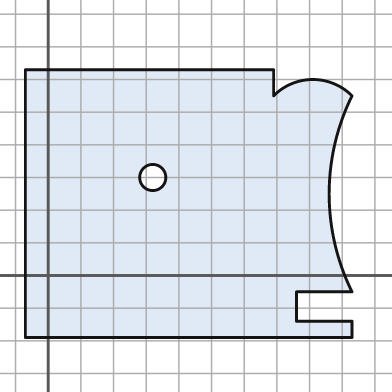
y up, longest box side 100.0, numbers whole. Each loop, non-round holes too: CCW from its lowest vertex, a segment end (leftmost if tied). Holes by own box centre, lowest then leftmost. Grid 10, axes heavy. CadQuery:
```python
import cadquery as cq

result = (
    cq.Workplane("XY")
    .moveTo(-7.0, -19.0)
    .lineTo(93.0, -19.0)
    .lineTo(93.0, -14.0)
    .lineTo(76.0, -14.0)
    .lineTo(76.0, -5.0)
    .lineTo(93.0, -5.0)
    .threePointArc((86.0, 25.0), (93.0, 55.0))
    .threePointArc((81.0, 60.0), (69.0, 55.0))
    .lineTo(69.0, 63.0)
    .lineTo(-7.0, 63.0)
    .close()
    .moveTo(32.0, 30.0)
    .circle(4.0)
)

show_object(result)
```